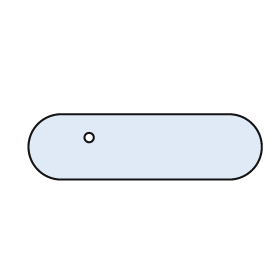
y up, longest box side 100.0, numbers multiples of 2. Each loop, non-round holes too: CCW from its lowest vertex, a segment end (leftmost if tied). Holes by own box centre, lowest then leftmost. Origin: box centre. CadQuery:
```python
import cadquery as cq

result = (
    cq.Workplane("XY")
    .moveTo(-36.0, -14.0)
    .lineTo(36.0, -14.0)
    .threePointArc((50.0, 0.0), (36.0, 14.0))
    .lineTo(-36.0, 14.0)
    .threePointArc((-50.0, 0.0), (-36.0, -14.0))
    .close()
    .moveTo(-24.0, 4.0)
    .circle(2.0)
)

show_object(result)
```